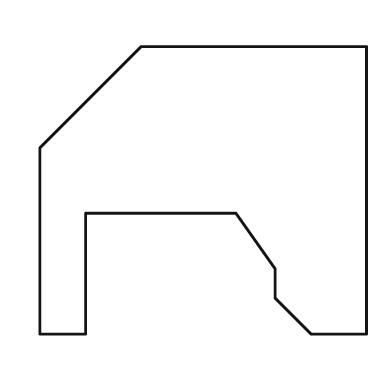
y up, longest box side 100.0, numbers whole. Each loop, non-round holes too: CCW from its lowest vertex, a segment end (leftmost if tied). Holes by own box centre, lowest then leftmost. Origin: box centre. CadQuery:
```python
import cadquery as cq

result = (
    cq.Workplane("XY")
    .moveTo(-50.0, -44.0)
    .lineTo(-36.0, -44.0)
    .lineTo(-36.0, -7.0)
    .lineTo(10.0, -7.0)
    .lineTo(22.0, -24.0)
    .lineTo(22.0, -33.0)
    .lineTo(33.0, -44.0)
    .lineTo(50.0, -44.0)
    .lineTo(50.0, 44.0)
    .lineTo(-19.0, 44.0)
    .lineTo(-50.0, 13.0)
    .close()
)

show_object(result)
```